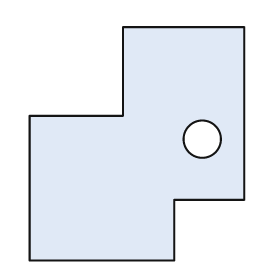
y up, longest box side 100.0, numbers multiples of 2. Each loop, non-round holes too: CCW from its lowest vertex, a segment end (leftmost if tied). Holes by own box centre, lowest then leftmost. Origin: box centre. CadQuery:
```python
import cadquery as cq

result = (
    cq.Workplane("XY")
    .moveTo(-46.0, -50.0)
    .lineTo(16.0, -50.0)
    .lineTo(16.0, -24.0)
    .lineTo(46.0, -24.0)
    .lineTo(46.0, 50.0)
    .lineTo(-6.0, 50.0)
    .lineTo(-6.0, 12.0)
    .lineTo(-46.0, 12.0)
    .close()
    .moveTo(28.0, 2.0)
    .circle(8.0)
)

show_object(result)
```